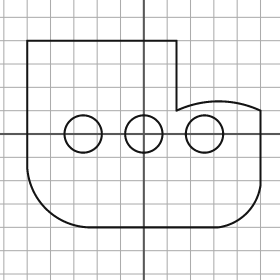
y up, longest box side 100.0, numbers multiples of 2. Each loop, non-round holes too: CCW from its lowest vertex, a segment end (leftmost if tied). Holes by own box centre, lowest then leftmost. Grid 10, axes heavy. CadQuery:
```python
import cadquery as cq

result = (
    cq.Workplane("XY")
    .moveTo(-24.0, -40.0)
    .lineTo(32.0, -40.0)
    .threePointArc((44.0, -34.0), (50.0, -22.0))
    .lineTo(50.0, 10.0)
    .threePointArc((32.0, 14.0), (14.0, 10.0))
    .lineTo(14.0, 40.0)
    .lineTo(-50.0, 40.0)
    .lineTo(-50.0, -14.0)
    .threePointArc((-42.0, -32.0), (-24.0, -40.0))
    .close()
    .moveTo(-26.0, 0.0)
    .circle(8.0)
    .moveTo(0.0, 0.0)
    .circle(8.0)
    .moveTo(26.0, 0.0)
    .circle(8.0)
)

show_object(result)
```